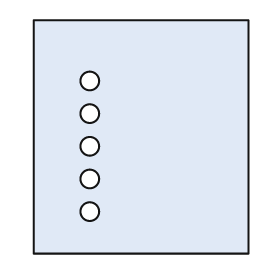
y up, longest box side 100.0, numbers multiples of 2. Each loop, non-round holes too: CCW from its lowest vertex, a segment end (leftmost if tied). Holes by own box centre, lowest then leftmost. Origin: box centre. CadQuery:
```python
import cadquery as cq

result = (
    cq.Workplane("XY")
    .moveTo(-46.0, -50.0)
    .lineTo(46.0, -50.0)
    .lineTo(46.0, 50.0)
    .lineTo(-46.0, 50.0)
    .close()
    .moveTo(-22.0, -32.0)
    .circle(4.0)
    .moveTo(-22.0, -18.0)
    .circle(4.0)
    .moveTo(-22.0, -4.0)
    .circle(4.0)
    .moveTo(-22.0, 10.0)
    .circle(4.0)
    .moveTo(-22.0, 24.0)
    .circle(4.0)
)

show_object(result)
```